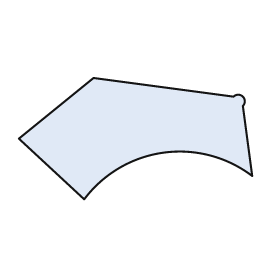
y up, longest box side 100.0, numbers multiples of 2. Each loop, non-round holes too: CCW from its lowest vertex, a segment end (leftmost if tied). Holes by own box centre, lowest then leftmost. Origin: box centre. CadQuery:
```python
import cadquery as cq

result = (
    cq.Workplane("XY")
    .moveTo(-22.0, -26.0)
    .threePointArc((12.0, -6.0), (50.0, -16.0))
    .lineTo(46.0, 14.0)
    .threePointArc((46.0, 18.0), (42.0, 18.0))
    .lineTo(-18.0, 26.0)
    .lineTo(-50.0, 0.0)
    .close()
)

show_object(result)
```